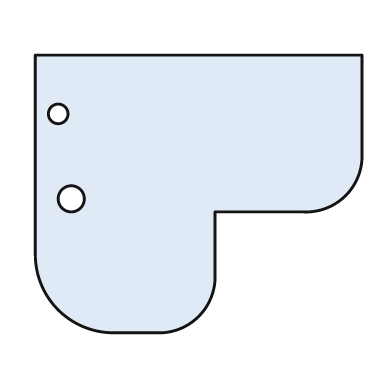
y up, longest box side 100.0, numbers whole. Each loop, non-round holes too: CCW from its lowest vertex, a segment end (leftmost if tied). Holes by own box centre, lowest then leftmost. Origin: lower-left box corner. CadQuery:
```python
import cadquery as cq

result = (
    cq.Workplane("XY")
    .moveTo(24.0, 0.0)
    .lineTo(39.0, 0.0)
    .threePointArc((50.0, 5.0), (55.0, 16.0))
    .lineTo(55.0, 37.0)
    .lineTo(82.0, 37.0)
    .threePointArc((95.0, 42.0), (100.0, 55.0))
    .lineTo(100.0, 85.0)
    .lineTo(0.0, 85.0)
    .lineTo(0.0, 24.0)
    .threePointArc((7.0, 7.0), (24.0, 0.0))
    .close()
    .moveTo(11.0, 41.0)
    .circle(4.0)
    .moveTo(7.0, 67.0)
    .circle(3.0)
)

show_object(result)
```